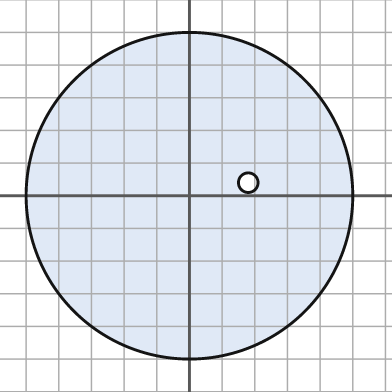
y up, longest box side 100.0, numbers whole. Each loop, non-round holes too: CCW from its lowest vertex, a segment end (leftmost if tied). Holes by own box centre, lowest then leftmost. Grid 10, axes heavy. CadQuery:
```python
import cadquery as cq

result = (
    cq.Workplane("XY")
    .moveTo(0.0, 0.0)
    .circle(50.0)
    .moveTo(18.0, 4.0)
    .circle(3.0)
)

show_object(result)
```